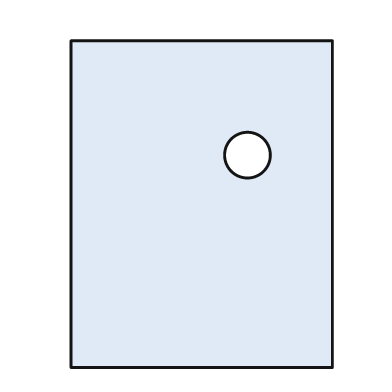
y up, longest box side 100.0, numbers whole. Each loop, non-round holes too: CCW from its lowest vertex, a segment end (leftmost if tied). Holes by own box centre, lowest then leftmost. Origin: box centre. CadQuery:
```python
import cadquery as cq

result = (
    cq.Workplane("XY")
    .moveTo(-40.0, -50.0)
    .lineTo(40.0, -50.0)
    .lineTo(40.0, 50.0)
    .lineTo(-40.0, 50.0)
    .close()
    .moveTo(14.0, 15.0)
    .circle(7.0)
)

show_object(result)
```